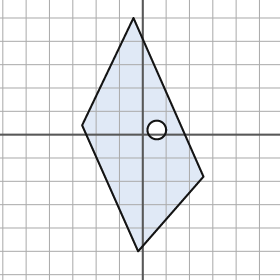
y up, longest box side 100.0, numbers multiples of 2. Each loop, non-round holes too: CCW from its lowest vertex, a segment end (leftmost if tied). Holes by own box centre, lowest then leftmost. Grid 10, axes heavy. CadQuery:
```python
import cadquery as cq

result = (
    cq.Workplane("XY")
    .moveTo(-2.0, -50.0)
    .lineTo(26.0, -18.0)
    .lineTo(-4.0, 50.0)
    .lineTo(-26.0, 4.0)
    .close()
    .moveTo(6.0, 2.0)
    .circle(4.0)
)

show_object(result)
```